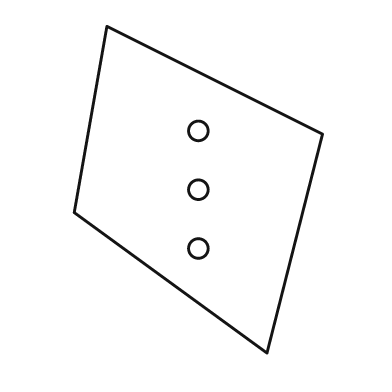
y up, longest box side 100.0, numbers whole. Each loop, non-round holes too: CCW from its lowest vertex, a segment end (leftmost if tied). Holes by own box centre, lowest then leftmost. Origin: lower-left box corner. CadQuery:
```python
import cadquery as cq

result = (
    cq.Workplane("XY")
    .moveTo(59.0, 0.0)
    .lineTo(76.0, 67.0)
    .lineTo(10.0, 100.0)
    .lineTo(0.0, 43.0)
    .close()
    .moveTo(38.0, 32.0)
    .circle(3.0)
    .moveTo(38.0, 50.0)
    .circle(3.0)
    .moveTo(38.0, 68.0)
    .circle(3.0)
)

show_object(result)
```